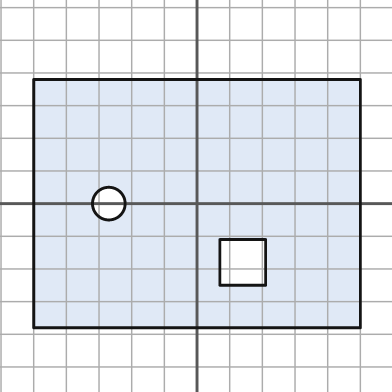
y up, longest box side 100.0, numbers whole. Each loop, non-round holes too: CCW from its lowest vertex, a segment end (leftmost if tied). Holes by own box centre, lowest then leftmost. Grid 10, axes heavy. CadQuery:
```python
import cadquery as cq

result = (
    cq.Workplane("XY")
    .moveTo(-50.0, -38.0)
    .lineTo(50.0, -38.0)
    .lineTo(50.0, 38.0)
    .lineTo(-50.0, 38.0)
    .close()
    .moveTo(7.0, -25.0)
    .lineTo(21.0, -25.0)
    .lineTo(21.0, -11.0)
    .lineTo(7.0, -11.0)
    .close()
    .moveTo(-27.0, 0.0)
    .circle(5.0)
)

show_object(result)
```